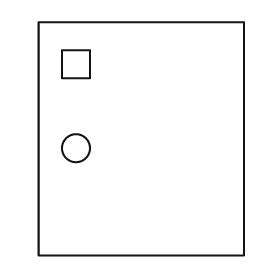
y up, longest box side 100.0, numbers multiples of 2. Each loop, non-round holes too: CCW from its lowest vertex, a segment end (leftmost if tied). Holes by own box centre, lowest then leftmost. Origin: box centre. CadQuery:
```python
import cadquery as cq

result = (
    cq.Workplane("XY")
    .moveTo(-44.0, -50.0)
    .lineTo(44.0, -50.0)
    .lineTo(44.0, 50.0)
    .lineTo(-44.0, 50.0)
    .close()
    .moveTo(-28.0, -4.0)
    .circle(6.0)
    .moveTo(-34.0, 26.0)
    .lineTo(-22.0, 26.0)
    .lineTo(-22.0, 38.0)
    .lineTo(-34.0, 38.0)
    .close()
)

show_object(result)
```